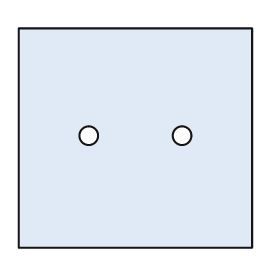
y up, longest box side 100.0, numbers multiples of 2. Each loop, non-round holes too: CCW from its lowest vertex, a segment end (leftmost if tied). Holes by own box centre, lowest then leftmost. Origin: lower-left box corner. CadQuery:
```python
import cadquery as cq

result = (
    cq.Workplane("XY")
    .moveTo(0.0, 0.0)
    .lineTo(100.0, 0.0)
    .lineTo(100.0, 94.0)
    .lineTo(0.0, 94.0)
    .close()
    .moveTo(30.0, 48.0)
    .circle(4.0)
    .moveTo(70.0, 48.0)
    .circle(4.0)
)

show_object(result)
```